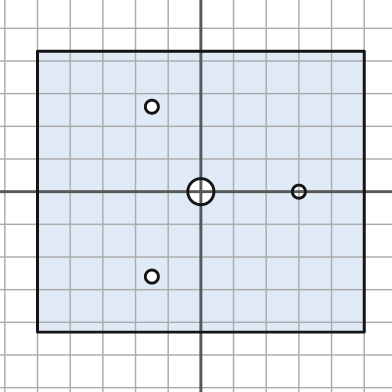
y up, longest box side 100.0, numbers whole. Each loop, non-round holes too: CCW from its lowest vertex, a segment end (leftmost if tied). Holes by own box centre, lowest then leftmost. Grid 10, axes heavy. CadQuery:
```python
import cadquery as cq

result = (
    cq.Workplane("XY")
    .moveTo(-50.0, -43.0)
    .lineTo(50.0, -43.0)
    .lineTo(50.0, 43.0)
    .lineTo(-50.0, 43.0)
    .close()
    .moveTo(-15.0, -26.0)
    .circle(2.0)
    .moveTo(0.0, 0.0)
    .circle(4.0)
    .moveTo(30.0, 0.0)
    .circle(2.0)
    .moveTo(-15.0, 26.0)
    .circle(2.0)
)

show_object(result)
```